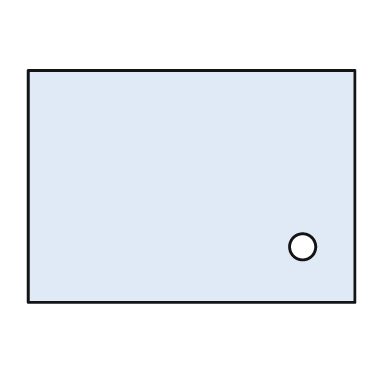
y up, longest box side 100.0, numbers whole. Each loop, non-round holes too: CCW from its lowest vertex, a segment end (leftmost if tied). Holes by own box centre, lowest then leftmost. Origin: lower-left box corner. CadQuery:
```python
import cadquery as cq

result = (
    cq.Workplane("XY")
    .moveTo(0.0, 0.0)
    .lineTo(100.0, 0.0)
    .lineTo(100.0, 71.0)
    .lineTo(0.0, 71.0)
    .close()
    .moveTo(84.0, 17.0)
    .circle(4.0)
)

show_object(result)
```